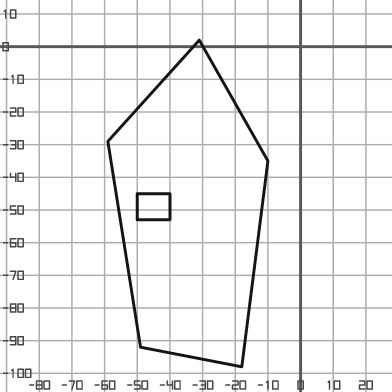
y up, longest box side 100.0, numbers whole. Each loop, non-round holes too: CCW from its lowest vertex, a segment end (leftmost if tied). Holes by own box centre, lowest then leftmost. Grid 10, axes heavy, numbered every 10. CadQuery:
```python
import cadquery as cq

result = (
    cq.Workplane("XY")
    .moveTo(-18.0, -98.0)
    .lineTo(-10.0, -35.0)
    .lineTo(-31.0, 2.0)
    .lineTo(-59.0, -29.0)
    .lineTo(-49.0, -92.0)
    .close()
    .moveTo(-50.0, -53.0)
    .lineTo(-40.0, -53.0)
    .lineTo(-40.0, -45.0)
    .lineTo(-50.0, -45.0)
    .close()
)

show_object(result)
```